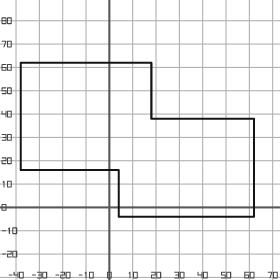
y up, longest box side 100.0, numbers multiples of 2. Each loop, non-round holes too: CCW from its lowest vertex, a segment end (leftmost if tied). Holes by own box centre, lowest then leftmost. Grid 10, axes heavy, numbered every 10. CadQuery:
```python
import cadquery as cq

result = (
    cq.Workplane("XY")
    .moveTo(4.0, -4.0)
    .lineTo(62.0, -4.0)
    .lineTo(62.0, 38.0)
    .lineTo(18.0, 38.0)
    .lineTo(18.0, 62.0)
    .lineTo(-38.0, 62.0)
    .lineTo(-38.0, 16.0)
    .lineTo(4.0, 16.0)
    .close()
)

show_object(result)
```